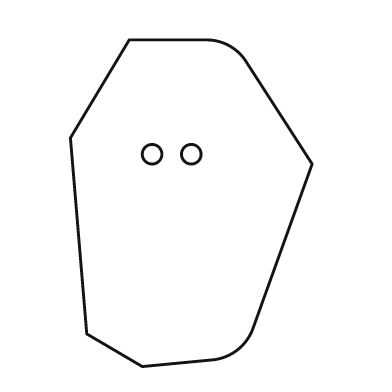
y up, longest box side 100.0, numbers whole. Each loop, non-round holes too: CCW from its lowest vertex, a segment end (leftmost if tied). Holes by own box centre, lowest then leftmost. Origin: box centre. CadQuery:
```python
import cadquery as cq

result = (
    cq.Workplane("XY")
    .moveTo(-15.0, -50.0)
    .lineTo(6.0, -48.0)
    .threePointArc((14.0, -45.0), (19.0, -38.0))
    .lineTo(37.0, 12.0)
    .lineTo(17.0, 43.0)
    .threePointArc((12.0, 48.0), (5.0, 50.0))
    .lineTo(-19.0, 50.0)
    .lineTo(-37.0, 20.0)
    .lineTo(-32.0, -40.0)
    .close()
    .moveTo(-12.0, 15.0)
    .circle(3.0)
    .moveTo(0.0, 15.0)
    .circle(3.0)
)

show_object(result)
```